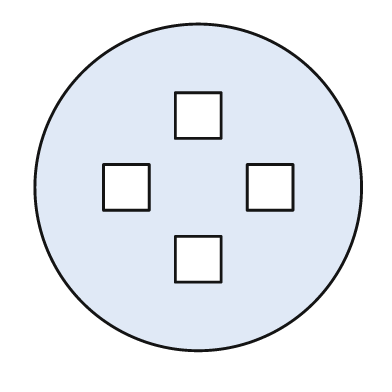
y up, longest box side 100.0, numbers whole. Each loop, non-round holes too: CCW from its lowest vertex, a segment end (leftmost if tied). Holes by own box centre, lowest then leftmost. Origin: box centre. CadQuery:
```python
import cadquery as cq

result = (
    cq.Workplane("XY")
    .moveTo(0.0, 0.0)
    .circle(50.0)
    .moveTo(-7.0, -29.0)
    .lineTo(7.0, -29.0)
    .lineTo(7.0, -15.0)
    .lineTo(-7.0, -15.0)
    .close()
    .moveTo(-29.0, -7.0)
    .lineTo(-15.0, -7.0)
    .lineTo(-15.0, 7.0)
    .lineTo(-29.0, 7.0)
    .close()
    .moveTo(15.0, -7.0)
    .lineTo(29.0, -7.0)
    .lineTo(29.0, 7.0)
    .lineTo(15.0, 7.0)
    .close()
    .moveTo(-7.0, 15.0)
    .lineTo(7.0, 15.0)
    .lineTo(7.0, 29.0)
    .lineTo(-7.0, 29.0)
    .close()
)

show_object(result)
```